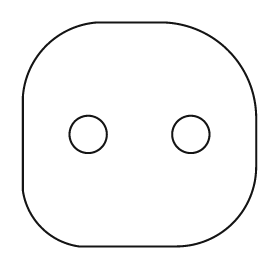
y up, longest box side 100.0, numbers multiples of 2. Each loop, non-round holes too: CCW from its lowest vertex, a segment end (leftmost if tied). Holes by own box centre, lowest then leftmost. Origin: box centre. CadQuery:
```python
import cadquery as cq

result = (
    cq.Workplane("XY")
    .moveTo(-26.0, -48.0)
    .lineTo(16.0, -48.0)
    .threePointArc((40.0, -38.0), (50.0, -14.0))
    .lineTo(50.0, 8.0)
    .threePointArc((38.0, 36.0), (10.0, 48.0))
    .lineTo(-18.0, 48.0)
    .threePointArc((-40.0, 38.0), (-50.0, 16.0))
    .lineTo(-50.0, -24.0)
    .threePointArc((-42.0, -40.0), (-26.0, -48.0))
    .close()
    .moveTo(-22.0, 0.0)
    .circle(8.0)
    .moveTo(22.0, 0.0)
    .circle(8.0)
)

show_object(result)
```